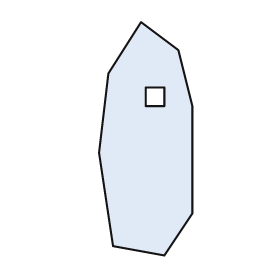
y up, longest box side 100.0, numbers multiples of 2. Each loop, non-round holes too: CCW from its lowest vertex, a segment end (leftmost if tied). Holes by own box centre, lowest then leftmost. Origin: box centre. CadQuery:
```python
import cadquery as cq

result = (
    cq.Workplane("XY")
    .moveTo(8.0, -50.0)
    .lineTo(20.0, -32.0)
    .lineTo(20.0, 14.0)
    .lineTo(14.0, 38.0)
    .lineTo(-2.0, 50.0)
    .lineTo(-16.0, 28.0)
    .lineTo(-20.0, -6.0)
    .lineTo(-14.0, -46.0)
    .close()
    .moveTo(0.0, 14.0)
    .lineTo(8.0, 14.0)
    .lineTo(8.0, 22.0)
    .lineTo(0.0, 22.0)
    .close()
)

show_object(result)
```